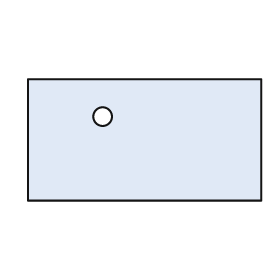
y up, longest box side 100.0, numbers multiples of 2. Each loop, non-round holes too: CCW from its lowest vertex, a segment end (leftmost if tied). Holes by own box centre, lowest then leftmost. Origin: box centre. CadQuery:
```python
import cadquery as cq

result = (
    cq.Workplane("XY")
    .moveTo(-50.0, -26.0)
    .lineTo(50.0, -26.0)
    .lineTo(50.0, 26.0)
    .lineTo(-50.0, 26.0)
    .close()
    .moveTo(-18.0, 10.0)
    .circle(4.0)
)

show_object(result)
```